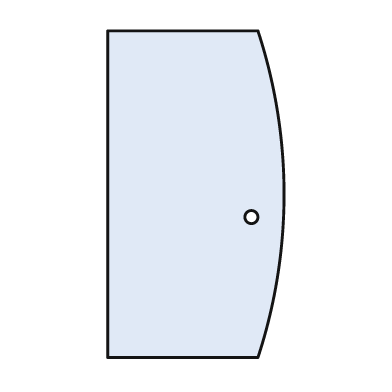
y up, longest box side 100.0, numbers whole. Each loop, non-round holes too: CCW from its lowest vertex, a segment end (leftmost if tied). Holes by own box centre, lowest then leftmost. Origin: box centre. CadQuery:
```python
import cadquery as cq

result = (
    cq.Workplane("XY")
    .moveTo(-27.0, -50.0)
    .lineTo(19.0, -50.0)
    .threePointArc((27.0, 0.0), (19.0, 50.0))
    .lineTo(-27.0, 50.0)
    .close()
    .moveTo(17.0, -7.0)
    .circle(2.0)
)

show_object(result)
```